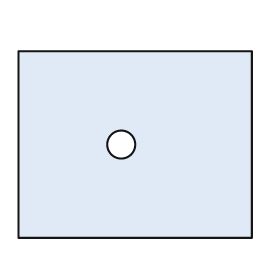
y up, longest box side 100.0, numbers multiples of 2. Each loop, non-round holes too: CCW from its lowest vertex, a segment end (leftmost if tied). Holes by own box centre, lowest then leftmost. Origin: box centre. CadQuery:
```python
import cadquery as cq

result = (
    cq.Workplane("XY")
    .moveTo(-50.0, -40.0)
    .lineTo(50.0, -40.0)
    .lineTo(50.0, 40.0)
    .lineTo(-50.0, 40.0)
    .close()
    .moveTo(-6.0, 0.0)
    .circle(6.0)
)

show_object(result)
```